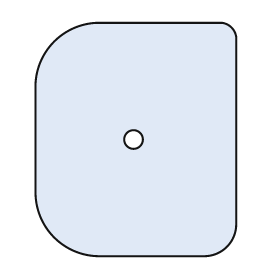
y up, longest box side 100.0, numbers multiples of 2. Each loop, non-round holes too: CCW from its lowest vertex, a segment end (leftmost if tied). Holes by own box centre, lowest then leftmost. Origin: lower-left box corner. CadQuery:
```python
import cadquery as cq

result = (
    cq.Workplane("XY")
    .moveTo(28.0, 0.0)
    .lineTo(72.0, 0.0)
    .threePointArc((82.0, 4.0), (86.0, 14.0))
    .lineTo(86.0, 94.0)
    .threePointArc((84.0, 98.0), (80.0, 100.0))
    .lineTo(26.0, 100.0)
    .threePointArc((8.0, 92.0), (0.0, 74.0))
    .lineTo(0.0, 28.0)
    .threePointArc((8.0, 8.0), (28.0, 0.0))
    .close()
    .moveTo(42.0, 50.0)
    .circle(4.0)
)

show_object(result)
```